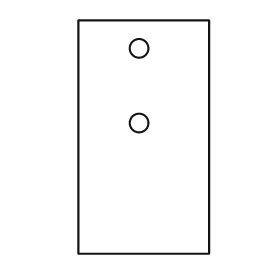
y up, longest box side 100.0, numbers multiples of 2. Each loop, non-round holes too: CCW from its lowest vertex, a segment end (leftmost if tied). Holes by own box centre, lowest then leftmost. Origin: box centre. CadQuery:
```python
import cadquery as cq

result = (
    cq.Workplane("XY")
    .moveTo(-28.0, -50.0)
    .lineTo(28.0, -50.0)
    .lineTo(28.0, 50.0)
    .lineTo(-28.0, 50.0)
    .close()
    .moveTo(-2.0, 6.0)
    .circle(4.0)
    .moveTo(-2.0, 38.0)
    .circle(4.0)
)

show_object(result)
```